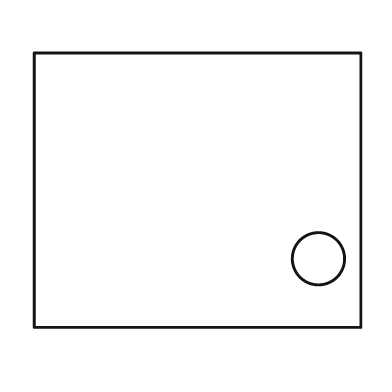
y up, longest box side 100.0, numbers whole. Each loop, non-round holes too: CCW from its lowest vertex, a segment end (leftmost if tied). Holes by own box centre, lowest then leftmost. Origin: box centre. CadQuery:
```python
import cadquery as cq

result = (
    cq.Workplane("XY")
    .moveTo(-50.0, -42.0)
    .lineTo(50.0, -42.0)
    .lineTo(50.0, 42.0)
    .lineTo(-50.0, 42.0)
    .close()
    .moveTo(37.0, -21.0)
    .circle(8.0)
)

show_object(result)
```